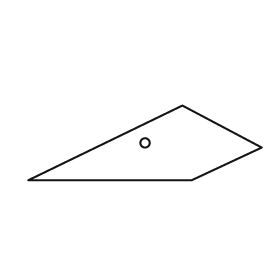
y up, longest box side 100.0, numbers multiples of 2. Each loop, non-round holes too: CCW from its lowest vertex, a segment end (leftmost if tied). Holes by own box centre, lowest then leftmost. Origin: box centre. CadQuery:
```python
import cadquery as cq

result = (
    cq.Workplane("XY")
    .moveTo(-50.0, -16.0)
    .lineTo(20.0, -16.0)
    .lineTo(50.0, -2.0)
    .lineTo(16.0, 16.0)
    .close()
    .moveTo(0.0, 0.0)
    .circle(2.0)
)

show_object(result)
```